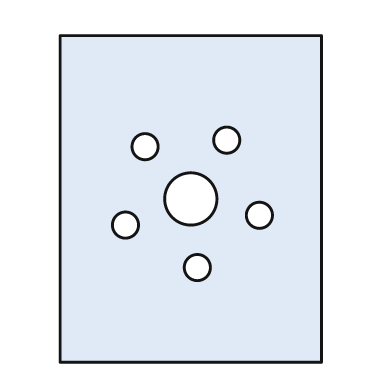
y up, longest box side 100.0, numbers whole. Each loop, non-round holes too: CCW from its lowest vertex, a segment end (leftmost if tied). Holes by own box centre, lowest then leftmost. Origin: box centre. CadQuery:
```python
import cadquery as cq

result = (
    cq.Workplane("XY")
    .moveTo(-40.0, -50.0)
    .lineTo(40.0, -50.0)
    .lineTo(40.0, 50.0)
    .lineTo(-40.0, 50.0)
    .close()
    .moveTo(2.0, -21.0)
    .circle(4.0)
    .moveTo(-20.0, -8.0)
    .circle(4.0)
    .moveTo(21.0, -5.0)
    .circle(4.0)
    .moveTo(0.0, 0.0)
    .circle(8.0)
    .moveTo(-14.0, 16.0)
    .circle(4.0)
    .moveTo(11.0, 18.0)
    .circle(4.0)
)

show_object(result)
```